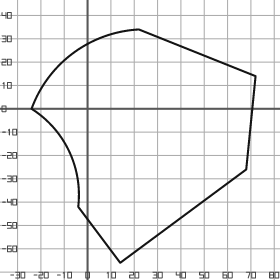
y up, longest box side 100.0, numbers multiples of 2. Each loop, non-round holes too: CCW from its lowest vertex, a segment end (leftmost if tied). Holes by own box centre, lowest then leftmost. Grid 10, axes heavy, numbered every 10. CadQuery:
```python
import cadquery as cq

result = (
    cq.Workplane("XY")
    .moveTo(14.0, -66.0)
    .lineTo(68.0, -26.0)
    .lineTo(72.0, 14.0)
    .lineTo(22.0, 34.0)
    .threePointArc((-6.0, 24.0), (-24.0, 0.0))
    .threePointArc((-8.0, -18.0), (-4.0, -42.0))
    .close()
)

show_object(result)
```